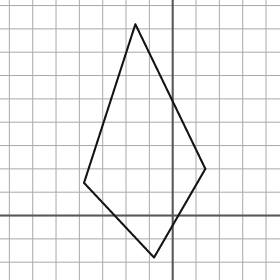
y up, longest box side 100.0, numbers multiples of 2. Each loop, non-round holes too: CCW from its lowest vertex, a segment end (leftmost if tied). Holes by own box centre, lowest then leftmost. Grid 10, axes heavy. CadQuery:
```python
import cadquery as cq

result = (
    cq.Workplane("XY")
    .moveTo(-8.0, -18.0)
    .lineTo(14.0, 20.0)
    .lineTo(-16.0, 82.0)
    .lineTo(-38.0, 14.0)
    .close()
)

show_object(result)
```